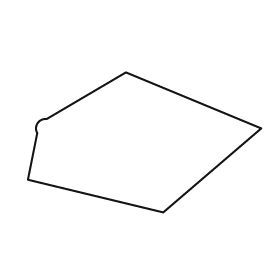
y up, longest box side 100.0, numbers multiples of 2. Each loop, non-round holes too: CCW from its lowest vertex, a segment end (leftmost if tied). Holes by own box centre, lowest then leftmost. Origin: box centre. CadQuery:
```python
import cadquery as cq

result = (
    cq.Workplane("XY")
    .moveTo(8.0, -30.0)
    .lineTo(50.0, 6.0)
    .lineTo(-8.0, 30.0)
    .lineTo(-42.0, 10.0)
    .threePointArc((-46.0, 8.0), (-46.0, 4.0))
    .lineTo(-50.0, -16.0)
    .close()
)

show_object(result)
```